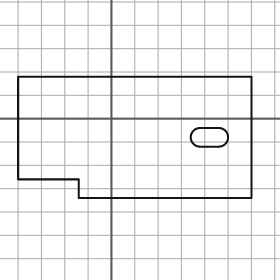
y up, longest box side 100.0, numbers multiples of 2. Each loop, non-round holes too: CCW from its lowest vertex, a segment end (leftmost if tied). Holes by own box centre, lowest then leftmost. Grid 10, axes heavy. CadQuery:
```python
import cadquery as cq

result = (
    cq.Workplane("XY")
    .moveTo(-14.0, -34.0)
    .lineTo(60.0, -34.0)
    .lineTo(60.0, 18.0)
    .lineTo(-40.0, 18.0)
    .lineTo(-40.0, -26.0)
    .lineTo(-14.0, -26.0)
    .close()
    .moveTo(38.0, -12.0)
    .lineTo(46.0, -12.0)
    .threePointArc((50.0, -8.0), (46.0, -4.0))
    .lineTo(38.0, -4.0)
    .threePointArc((34.0, -8.0), (38.0, -12.0))
    .close()
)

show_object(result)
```